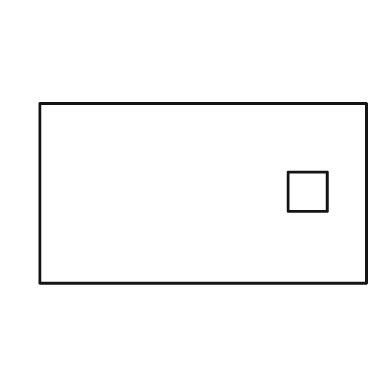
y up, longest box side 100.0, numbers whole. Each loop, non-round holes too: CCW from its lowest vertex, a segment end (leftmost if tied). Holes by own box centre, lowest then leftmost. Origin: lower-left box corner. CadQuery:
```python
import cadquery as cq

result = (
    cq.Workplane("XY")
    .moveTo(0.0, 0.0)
    .lineTo(100.0, 0.0)
    .lineTo(100.0, 55.0)
    .lineTo(0.0, 55.0)
    .close()
    .moveTo(76.0, 22.0)
    .lineTo(88.0, 22.0)
    .lineTo(88.0, 34.0)
    .lineTo(76.0, 34.0)
    .close()
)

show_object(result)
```